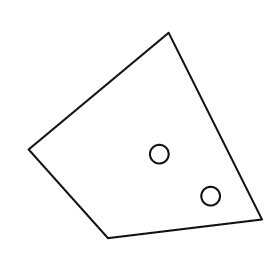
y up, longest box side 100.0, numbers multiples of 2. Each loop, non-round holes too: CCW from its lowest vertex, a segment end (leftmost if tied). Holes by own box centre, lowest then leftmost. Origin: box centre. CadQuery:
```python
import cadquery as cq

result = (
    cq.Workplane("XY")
    .moveTo(-16.0, -44.0)
    .lineTo(50.0, -36.0)
    .lineTo(10.0, 44.0)
    .lineTo(-50.0, -6.0)
    .close()
    .moveTo(28.0, -26.0)
    .circle(4.0)
    .moveTo(6.0, -8.0)
    .circle(4.0)
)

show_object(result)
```